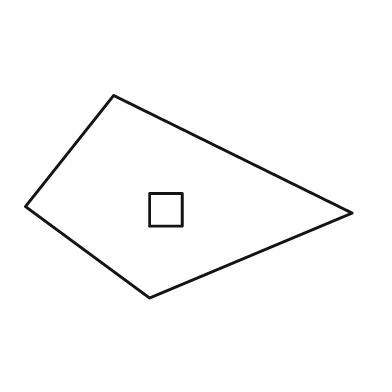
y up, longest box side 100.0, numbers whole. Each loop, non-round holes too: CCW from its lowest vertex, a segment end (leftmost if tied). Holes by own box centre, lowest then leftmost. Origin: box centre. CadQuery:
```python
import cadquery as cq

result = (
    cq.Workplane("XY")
    .moveTo(-12.0, -31.0)
    .lineTo(50.0, -5.0)
    .lineTo(-23.0, 31.0)
    .lineTo(-50.0, -3.0)
    .close()
    .moveTo(-12.0, -9.0)
    .lineTo(-2.0, -9.0)
    .lineTo(-2.0, 1.0)
    .lineTo(-12.0, 1.0)
    .close()
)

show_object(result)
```